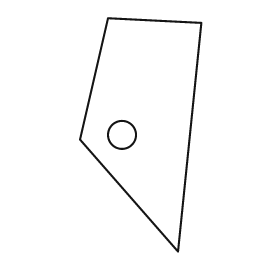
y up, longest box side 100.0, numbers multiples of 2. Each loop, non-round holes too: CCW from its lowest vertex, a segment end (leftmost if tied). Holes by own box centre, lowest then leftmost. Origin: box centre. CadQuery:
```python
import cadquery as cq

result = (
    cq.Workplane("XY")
    .moveTo(16.0, -50.0)
    .lineTo(26.0, 48.0)
    .lineTo(-14.0, 50.0)
    .lineTo(-26.0, -2.0)
    .close()
    .moveTo(-8.0, 0.0)
    .circle(6.0)
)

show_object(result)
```